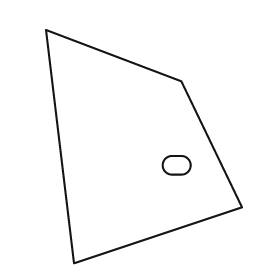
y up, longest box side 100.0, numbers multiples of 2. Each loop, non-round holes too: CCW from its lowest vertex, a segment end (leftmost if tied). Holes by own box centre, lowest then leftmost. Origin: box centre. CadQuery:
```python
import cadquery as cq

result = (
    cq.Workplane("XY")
    .moveTo(-30.0, -50.0)
    .lineTo(42.0, -26.0)
    .lineTo(16.0, 28.0)
    .lineTo(-42.0, 50.0)
    .close()
    .moveTo(12.0, -12.0)
    .lineTo(16.0, -12.0)
    .threePointArc((20.0, -8.0), (16.0, -4.0))
    .lineTo(12.0, -4.0)
    .threePointArc((8.0, -8.0), (12.0, -12.0))
    .close()
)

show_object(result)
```